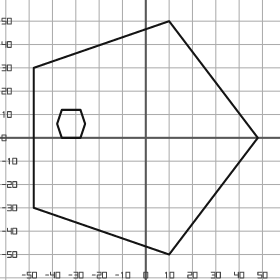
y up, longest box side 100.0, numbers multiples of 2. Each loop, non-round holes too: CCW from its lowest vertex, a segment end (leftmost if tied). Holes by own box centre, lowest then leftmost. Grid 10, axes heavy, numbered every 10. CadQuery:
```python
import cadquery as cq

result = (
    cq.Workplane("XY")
    .moveTo(10.0, -50.0)
    .lineTo(48.0, 0.0)
    .lineTo(10.0, 50.0)
    .lineTo(-48.0, 30.0)
    .lineTo(-48.0, -30.0)
    .close()
    .moveTo(-36.0, 0.0)
    .lineTo(-28.0, 0.0)
    .lineTo(-26.0, 6.0)
    .lineTo(-28.0, 12.0)
    .lineTo(-36.0, 12.0)
    .lineTo(-38.0, 6.0)
    .close()
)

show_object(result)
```